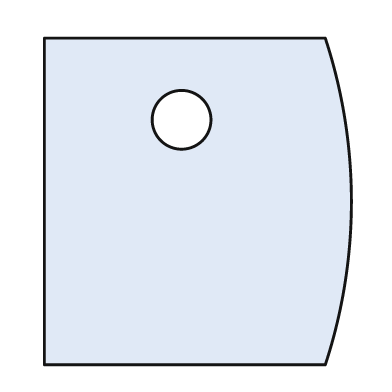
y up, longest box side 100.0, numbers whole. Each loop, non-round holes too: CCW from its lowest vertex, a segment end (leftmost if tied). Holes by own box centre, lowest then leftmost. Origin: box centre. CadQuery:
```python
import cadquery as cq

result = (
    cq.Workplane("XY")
    .moveTo(-47.0, -50.0)
    .lineTo(39.0, -50.0)
    .threePointArc((47.0, 0.0), (39.0, 50.0))
    .lineTo(-47.0, 50.0)
    .close()
    .moveTo(-5.0, 25.0)
    .circle(9.0)
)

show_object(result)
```